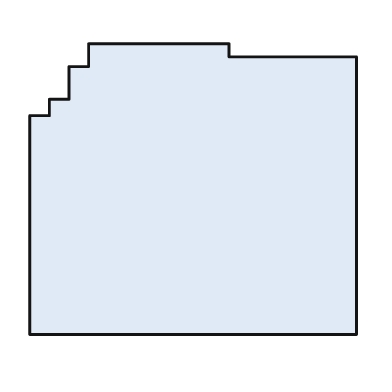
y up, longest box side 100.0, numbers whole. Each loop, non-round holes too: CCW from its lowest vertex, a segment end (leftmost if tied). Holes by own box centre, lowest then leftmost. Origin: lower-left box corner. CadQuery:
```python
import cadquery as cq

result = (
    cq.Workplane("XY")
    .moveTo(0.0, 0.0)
    .lineTo(100.0, 0.0)
    .lineTo(100.0, 85.0)
    .lineTo(61.0, 85.0)
    .lineTo(61.0, 89.0)
    .lineTo(18.0, 89.0)
    .lineTo(18.0, 82.0)
    .lineTo(12.0, 82.0)
    .lineTo(12.0, 72.0)
    .lineTo(6.0, 72.0)
    .lineTo(6.0, 67.0)
    .lineTo(0.0, 67.0)
    .close()
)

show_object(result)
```